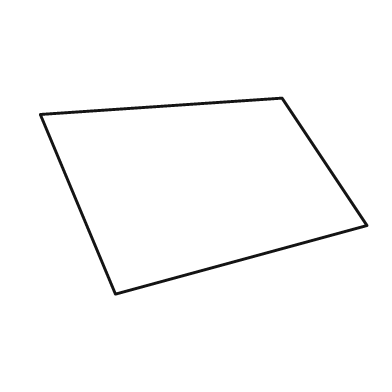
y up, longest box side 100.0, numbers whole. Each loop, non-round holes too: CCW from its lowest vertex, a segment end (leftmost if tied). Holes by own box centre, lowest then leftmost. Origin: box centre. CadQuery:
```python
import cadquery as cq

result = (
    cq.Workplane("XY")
    .moveTo(-27.0, -30.0)
    .lineTo(50.0, -9.0)
    .lineTo(24.0, 30.0)
    .lineTo(-50.0, 25.0)
    .close()
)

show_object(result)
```